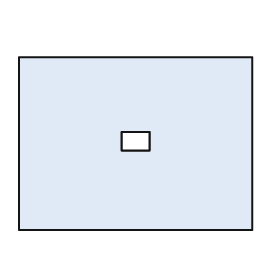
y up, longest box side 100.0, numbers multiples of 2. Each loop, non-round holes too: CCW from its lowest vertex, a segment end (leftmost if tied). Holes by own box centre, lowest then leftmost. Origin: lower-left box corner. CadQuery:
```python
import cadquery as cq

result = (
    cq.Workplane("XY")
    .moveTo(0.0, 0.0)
    .lineTo(100.0, 0.0)
    .lineTo(100.0, 74.0)
    .lineTo(0.0, 74.0)
    .close()
    .moveTo(44.0, 34.0)
    .lineTo(56.0, 34.0)
    .lineTo(56.0, 42.0)
    .lineTo(44.0, 42.0)
    .close()
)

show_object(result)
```